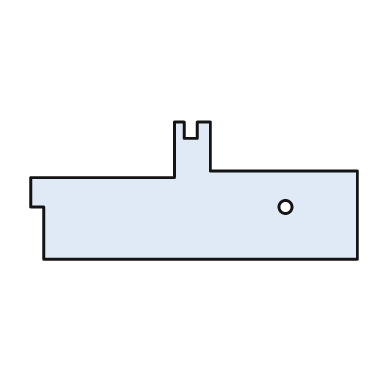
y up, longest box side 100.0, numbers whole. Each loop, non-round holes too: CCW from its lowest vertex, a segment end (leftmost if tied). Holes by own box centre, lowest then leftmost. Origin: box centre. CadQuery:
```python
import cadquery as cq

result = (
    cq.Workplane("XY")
    .moveTo(-46.0, -21.0)
    .lineTo(50.0, -21.0)
    .lineTo(50.0, 6.0)
    .lineTo(5.0, 6.0)
    .lineTo(5.0, 21.0)
    .lineTo(1.0, 21.0)
    .lineTo(1.0, 16.0)
    .lineTo(-3.0, 16.0)
    .lineTo(-3.0, 21.0)
    .lineTo(-6.0, 21.0)
    .lineTo(-6.0, 4.0)
    .lineTo(-50.0, 4.0)
    .lineTo(-50.0, -5.0)
    .lineTo(-46.0, -5.0)
    .close()
    .moveTo(28.0, -5.0)
    .circle(2.0)
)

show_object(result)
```